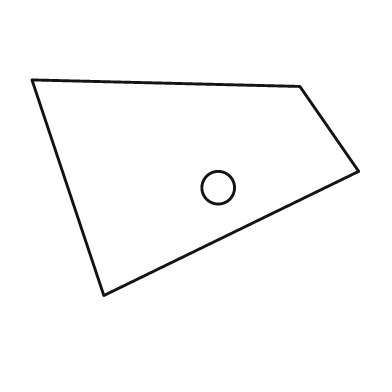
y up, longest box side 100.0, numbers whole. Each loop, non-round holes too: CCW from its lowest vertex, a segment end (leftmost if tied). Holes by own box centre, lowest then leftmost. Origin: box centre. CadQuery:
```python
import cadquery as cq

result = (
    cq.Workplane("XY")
    .moveTo(-28.0, -33.0)
    .lineTo(50.0, 5.0)
    .lineTo(32.0, 31.0)
    .lineTo(-50.0, 33.0)
    .close()
    .moveTo(7.0, 0.0)
    .circle(5.0)
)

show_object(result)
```